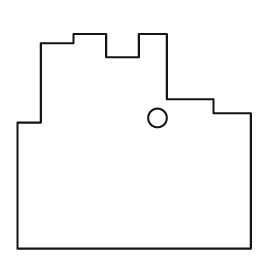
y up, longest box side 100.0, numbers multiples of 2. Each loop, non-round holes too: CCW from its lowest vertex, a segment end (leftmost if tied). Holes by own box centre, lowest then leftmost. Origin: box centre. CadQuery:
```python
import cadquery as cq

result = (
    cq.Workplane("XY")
    .moveTo(-50.0, -46.0)
    .lineTo(50.0, -46.0)
    .lineTo(50.0, 12.0)
    .lineTo(34.0, 12.0)
    .lineTo(34.0, 18.0)
    .lineTo(14.0, 18.0)
    .lineTo(14.0, 46.0)
    .lineTo(2.0, 46.0)
    .lineTo(2.0, 36.0)
    .lineTo(-12.0, 36.0)
    .lineTo(-12.0, 46.0)
    .lineTo(-26.0, 46.0)
    .lineTo(-26.0, 42.0)
    .lineTo(-40.0, 42.0)
    .lineTo(-40.0, 8.0)
    .lineTo(-50.0, 8.0)
    .close()
    .moveTo(10.0, 10.0)
    .circle(4.0)
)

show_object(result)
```